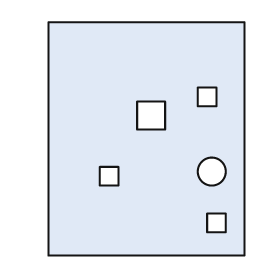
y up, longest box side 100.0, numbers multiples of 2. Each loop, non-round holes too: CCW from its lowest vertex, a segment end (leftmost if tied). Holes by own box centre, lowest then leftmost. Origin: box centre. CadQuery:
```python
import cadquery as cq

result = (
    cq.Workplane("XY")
    .moveTo(-42.0, -50.0)
    .lineTo(42.0, -50.0)
    .lineTo(42.0, 50.0)
    .lineTo(-42.0, 50.0)
    .close()
    .moveTo(26.0, -40.0)
    .lineTo(34.0, -40.0)
    .lineTo(34.0, -32.0)
    .lineTo(26.0, -32.0)
    .close()
    .moveTo(-20.0, -20.0)
    .lineTo(-12.0, -20.0)
    .lineTo(-12.0, -12.0)
    .lineTo(-20.0, -12.0)
    .close()
    .moveTo(28.0, -14.0)
    .circle(6.0)
    .moveTo(-4.0, 4.0)
    .lineTo(8.0, 4.0)
    .lineTo(8.0, 16.0)
    .lineTo(-4.0, 16.0)
    .close()
    .moveTo(22.0, 14.0)
    .lineTo(30.0, 14.0)
    .lineTo(30.0, 22.0)
    .lineTo(22.0, 22.0)
    .close()
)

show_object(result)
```